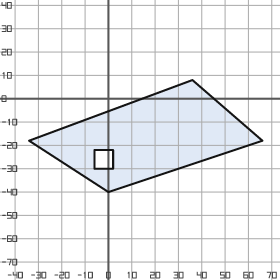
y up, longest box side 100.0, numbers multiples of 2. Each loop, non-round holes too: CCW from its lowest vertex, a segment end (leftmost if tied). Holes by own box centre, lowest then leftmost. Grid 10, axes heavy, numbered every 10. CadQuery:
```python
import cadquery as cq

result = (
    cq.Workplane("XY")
    .moveTo(0.0, -40.0)
    .lineTo(66.0, -18.0)
    .lineTo(36.0, 8.0)
    .lineTo(-34.0, -18.0)
    .close()
    .moveTo(-6.0, -30.0)
    .lineTo(2.0, -30.0)
    .lineTo(2.0, -22.0)
    .lineTo(-6.0, -22.0)
    .close()
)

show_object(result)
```